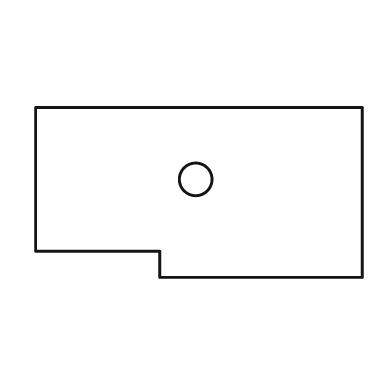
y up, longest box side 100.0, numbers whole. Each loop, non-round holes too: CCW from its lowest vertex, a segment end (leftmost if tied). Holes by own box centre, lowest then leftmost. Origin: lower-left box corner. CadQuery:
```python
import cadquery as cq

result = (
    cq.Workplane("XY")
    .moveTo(38.0, 0.0)
    .lineTo(100.0, 0.0)
    .lineTo(100.0, 52.0)
    .lineTo(0.0, 52.0)
    .lineTo(0.0, 8.0)
    .lineTo(38.0, 8.0)
    .close()
    .moveTo(49.0, 30.0)
    .circle(5.0)
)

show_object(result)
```